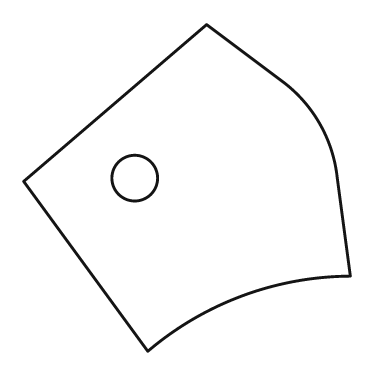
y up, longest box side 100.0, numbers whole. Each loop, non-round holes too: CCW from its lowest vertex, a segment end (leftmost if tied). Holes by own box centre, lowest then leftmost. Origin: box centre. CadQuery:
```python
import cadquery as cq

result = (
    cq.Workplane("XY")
    .moveTo(-12.0, -50.0)
    .threePointArc((17.0, -33.0), (50.0, -27.0))
    .lineTo(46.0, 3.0)
    .threePointArc((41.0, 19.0), (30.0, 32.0))
    .lineTo(6.0, 50.0)
    .lineTo(-50.0, 2.0)
    .close()
    .moveTo(-16.0, 3.0)
    .circle(7.0)
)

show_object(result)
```